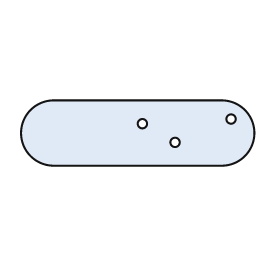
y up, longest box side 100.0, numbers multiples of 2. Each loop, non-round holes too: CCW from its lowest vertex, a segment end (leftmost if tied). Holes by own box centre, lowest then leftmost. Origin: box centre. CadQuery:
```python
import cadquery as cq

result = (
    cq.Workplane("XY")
    .moveTo(-36.0, -14.0)
    .lineTo(36.0, -14.0)
    .threePointArc((50.0, 0.0), (36.0, 14.0))
    .lineTo(-36.0, 14.0)
    .threePointArc((-50.0, 0.0), (-36.0, -14.0))
    .close()
    .moveTo(16.0, -4.0)
    .circle(2.0)
    .moveTo(2.0, 4.0)
    .circle(2.0)
    .moveTo(40.0, 6.0)
    .circle(2.0)
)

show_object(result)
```